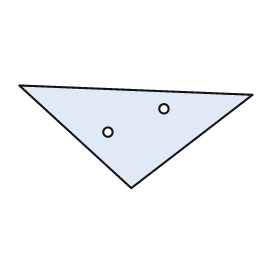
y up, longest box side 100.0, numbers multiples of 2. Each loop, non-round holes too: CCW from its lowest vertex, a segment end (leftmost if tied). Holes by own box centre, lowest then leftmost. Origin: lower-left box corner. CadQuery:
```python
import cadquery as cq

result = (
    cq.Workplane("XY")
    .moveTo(48.0, 0.0)
    .lineTo(100.0, 40.0)
    .lineTo(0.0, 44.0)
    .close()
    .moveTo(38.0, 24.0)
    .circle(2.0)
    .moveTo(62.0, 34.0)
    .circle(2.0)
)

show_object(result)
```